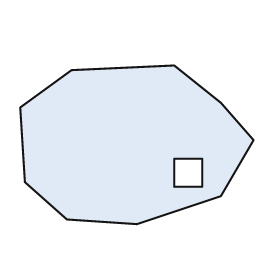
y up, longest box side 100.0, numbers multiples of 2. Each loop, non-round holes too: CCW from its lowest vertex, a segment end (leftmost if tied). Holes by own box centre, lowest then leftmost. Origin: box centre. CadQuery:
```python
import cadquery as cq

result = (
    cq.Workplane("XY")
    .moveTo(0.0, -34.0)
    .lineTo(36.0, -22.0)
    .lineTo(50.0, 2.0)
    .lineTo(36.0, 18.0)
    .lineTo(16.0, 34.0)
    .lineTo(-28.0, 32.0)
    .lineTo(-50.0, 16.0)
    .lineTo(-48.0, -16.0)
    .lineTo(-30.0, -32.0)
    .close()
    .moveTo(16.0, -18.0)
    .lineTo(28.0, -18.0)
    .lineTo(28.0, -6.0)
    .lineTo(16.0, -6.0)
    .close()
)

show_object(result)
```